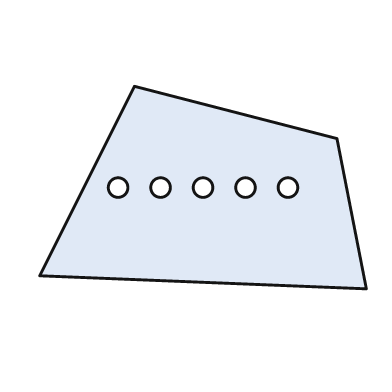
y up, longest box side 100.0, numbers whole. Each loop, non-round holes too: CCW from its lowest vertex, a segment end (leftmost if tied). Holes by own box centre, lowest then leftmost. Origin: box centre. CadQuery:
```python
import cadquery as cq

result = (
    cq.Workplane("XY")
    .moveTo(50.0, -31.0)
    .lineTo(41.0, 15.0)
    .lineTo(-21.0, 31.0)
    .lineTo(-50.0, -27.0)
    .close()
    .moveTo(-26.0, 0.0)
    .circle(3.0)
    .moveTo(-13.0, 0.0)
    .circle(3.0)
    .moveTo(0.0, 0.0)
    .circle(3.0)
    .moveTo(13.0, 0.0)
    .circle(3.0)
    .moveTo(26.0, 0.0)
    .circle(3.0)
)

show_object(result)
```